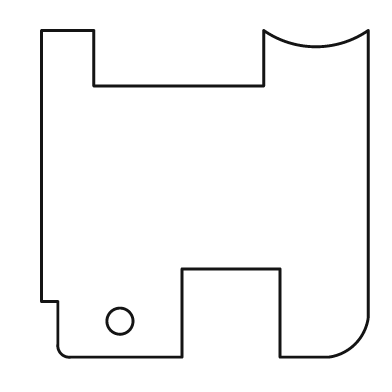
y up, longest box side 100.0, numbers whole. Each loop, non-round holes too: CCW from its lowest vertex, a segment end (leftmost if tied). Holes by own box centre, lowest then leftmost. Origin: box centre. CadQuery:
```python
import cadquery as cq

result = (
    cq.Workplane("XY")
    .moveTo(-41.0, -50.0)
    .lineTo(-7.0, -50.0)
    .lineTo(-7.0, -23.0)
    .lineTo(23.0, -23.0)
    .lineTo(23.0, -50.0)
    .lineTo(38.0, -50.0)
    .threePointArc((46.0, -46.0), (50.0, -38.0))
    .lineTo(50.0, 50.0)
    .threePointArc((34.0, 45.0), (18.0, 50.0))
    .lineTo(18.0, 33.0)
    .lineTo(-34.0, 33.0)
    .lineTo(-34.0, 50.0)
    .lineTo(-50.0, 50.0)
    .lineTo(-50.0, -33.0)
    .lineTo(-45.0, -33.0)
    .lineTo(-45.0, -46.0)
    .threePointArc((-44.0, -49.0), (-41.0, -50.0))
    .close()
    .moveTo(-26.0, -39.0)
    .circle(4.0)
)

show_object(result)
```